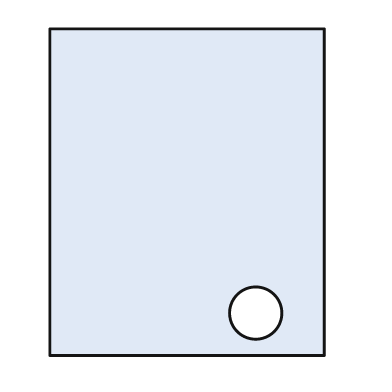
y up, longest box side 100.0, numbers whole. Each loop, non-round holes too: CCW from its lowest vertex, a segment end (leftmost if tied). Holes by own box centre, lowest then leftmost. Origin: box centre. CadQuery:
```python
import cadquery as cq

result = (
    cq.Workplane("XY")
    .moveTo(-42.0, -50.0)
    .lineTo(42.0, -50.0)
    .lineTo(42.0, 50.0)
    .lineTo(-42.0, 50.0)
    .close()
    .moveTo(21.0, -37.0)
    .circle(8.0)
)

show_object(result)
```